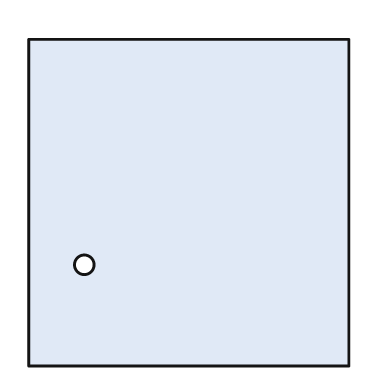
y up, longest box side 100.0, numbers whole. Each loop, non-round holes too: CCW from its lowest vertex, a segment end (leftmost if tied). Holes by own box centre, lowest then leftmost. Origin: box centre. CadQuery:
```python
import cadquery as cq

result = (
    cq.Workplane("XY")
    .moveTo(-49.0, -50.0)
    .lineTo(49.0, -50.0)
    .lineTo(49.0, 50.0)
    .lineTo(-49.0, 50.0)
    .close()
    .moveTo(-32.0, -19.0)
    .circle(3.0)
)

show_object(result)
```